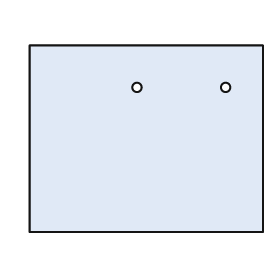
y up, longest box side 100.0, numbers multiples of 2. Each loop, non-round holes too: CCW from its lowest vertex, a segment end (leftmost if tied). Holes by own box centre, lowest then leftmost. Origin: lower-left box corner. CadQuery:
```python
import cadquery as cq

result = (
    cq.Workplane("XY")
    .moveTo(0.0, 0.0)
    .lineTo(100.0, 0.0)
    .lineTo(100.0, 80.0)
    .lineTo(0.0, 80.0)
    .close()
    .moveTo(46.0, 62.0)
    .circle(2.0)
    .moveTo(84.0, 62.0)
    .circle(2.0)
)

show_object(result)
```